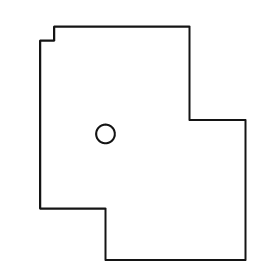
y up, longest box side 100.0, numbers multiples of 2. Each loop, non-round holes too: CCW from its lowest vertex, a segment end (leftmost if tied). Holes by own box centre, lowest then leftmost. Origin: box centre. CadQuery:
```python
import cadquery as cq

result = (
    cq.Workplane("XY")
    .moveTo(-16.0, -50.0)
    .lineTo(44.0, -50.0)
    .lineTo(44.0, 10.0)
    .lineTo(20.0, 10.0)
    .lineTo(20.0, 50.0)
    .lineTo(-38.0, 50.0)
    .lineTo(-38.0, 44.0)
    .lineTo(-44.0, 44.0)
    .lineTo(-44.0, -28.0)
    .lineTo(-16.0, -28.0)
    .close()
    .moveTo(-16.0, 4.0)
    .circle(4.0)
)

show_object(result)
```